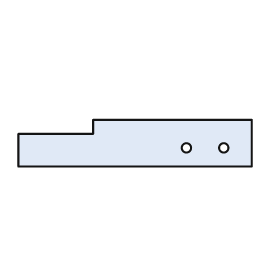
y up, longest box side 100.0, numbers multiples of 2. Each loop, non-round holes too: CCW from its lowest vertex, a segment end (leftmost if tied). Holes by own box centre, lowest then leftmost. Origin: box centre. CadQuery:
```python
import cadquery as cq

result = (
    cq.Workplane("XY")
    .moveTo(-50.0, -10.0)
    .lineTo(50.0, -10.0)
    .lineTo(50.0, 10.0)
    .lineTo(-18.0, 10.0)
    .lineTo(-18.0, 4.0)
    .lineTo(-50.0, 4.0)
    .close()
    .moveTo(22.0, -2.0)
    .circle(2.0)
    .moveTo(38.0, -2.0)
    .circle(2.0)
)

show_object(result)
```